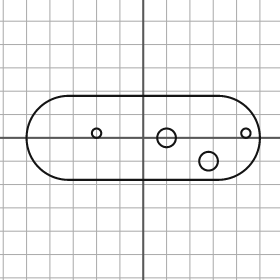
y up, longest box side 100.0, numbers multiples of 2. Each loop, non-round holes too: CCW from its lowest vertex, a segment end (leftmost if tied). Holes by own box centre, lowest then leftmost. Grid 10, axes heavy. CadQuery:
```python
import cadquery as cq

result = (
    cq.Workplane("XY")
    .moveTo(-32.0, -18.0)
    .lineTo(32.0, -18.0)
    .threePointArc((50.0, 0.0), (32.0, 18.0))
    .lineTo(-32.0, 18.0)
    .threePointArc((-50.0, 0.0), (-32.0, -18.0))
    .close()
    .moveTo(28.0, -10.0)
    .circle(4.0)
    .moveTo(10.0, 0.0)
    .circle(4.0)
    .moveTo(-20.0, 2.0)
    .circle(2.0)
    .moveTo(44.0, 2.0)
    .circle(2.0)
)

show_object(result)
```